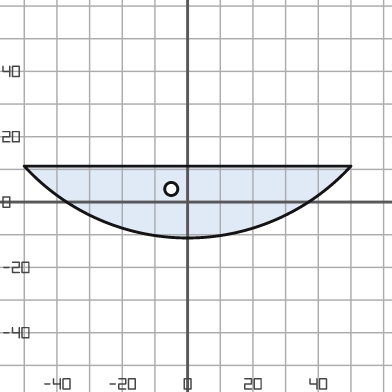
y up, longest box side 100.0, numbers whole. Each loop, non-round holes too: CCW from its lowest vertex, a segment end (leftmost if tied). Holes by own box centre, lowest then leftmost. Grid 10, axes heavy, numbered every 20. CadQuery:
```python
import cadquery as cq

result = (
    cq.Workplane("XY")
    .moveTo(-50.0, 11.0)
    .threePointArc((0.0, -11.0), (50.0, 11.0))
    .close()
    .moveTo(-5.0, 4.0)
    .circle(2.0)
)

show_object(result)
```